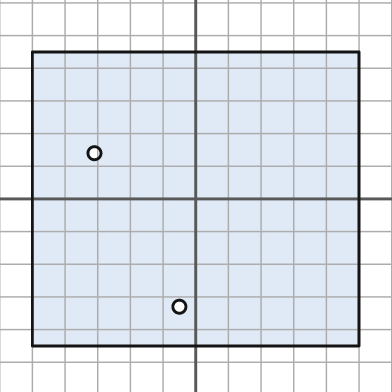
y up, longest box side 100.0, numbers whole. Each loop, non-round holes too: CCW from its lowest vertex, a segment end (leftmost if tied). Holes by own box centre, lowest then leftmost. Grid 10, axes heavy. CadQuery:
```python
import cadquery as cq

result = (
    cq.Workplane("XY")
    .moveTo(-50.0, -45.0)
    .lineTo(50.0, -45.0)
    .lineTo(50.0, 45.0)
    .lineTo(-50.0, 45.0)
    .close()
    .moveTo(-5.0, -33.0)
    .circle(2.0)
    .moveTo(-31.0, 14.0)
    .circle(2.0)
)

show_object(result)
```